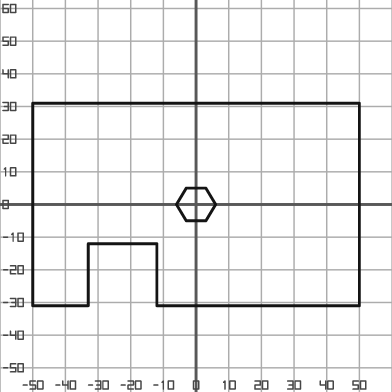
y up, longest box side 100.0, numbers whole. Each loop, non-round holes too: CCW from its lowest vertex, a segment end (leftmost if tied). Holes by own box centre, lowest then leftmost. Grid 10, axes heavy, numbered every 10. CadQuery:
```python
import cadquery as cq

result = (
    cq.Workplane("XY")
    .moveTo(-50.0, -31.0)
    .lineTo(-33.0, -31.0)
    .lineTo(-33.0, -12.0)
    .lineTo(-12.0, -12.0)
    .lineTo(-12.0, -31.0)
    .lineTo(50.0, -31.0)
    .lineTo(50.0, 31.0)
    .lineTo(-50.0, 31.0)
    .close()
    .moveTo(-3.0, -5.0)
    .lineTo(3.0, -5.0)
    .lineTo(6.0, 0.0)
    .lineTo(3.0, 5.0)
    .lineTo(-3.0, 5.0)
    .lineTo(-6.0, 0.0)
    .close()
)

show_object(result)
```